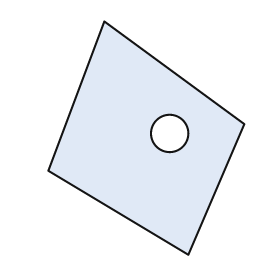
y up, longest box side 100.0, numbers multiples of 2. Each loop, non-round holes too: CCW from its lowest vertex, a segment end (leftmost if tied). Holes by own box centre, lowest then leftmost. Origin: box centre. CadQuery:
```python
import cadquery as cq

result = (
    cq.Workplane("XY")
    .moveTo(18.0, -50.0)
    .lineTo(42.0, 6.0)
    .lineTo(-18.0, 50.0)
    .lineTo(-42.0, -14.0)
    .close()
    .moveTo(10.0, 2.0)
    .circle(8.0)
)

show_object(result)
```